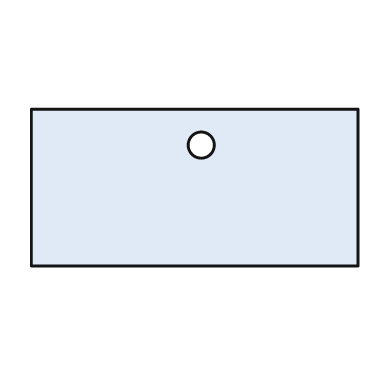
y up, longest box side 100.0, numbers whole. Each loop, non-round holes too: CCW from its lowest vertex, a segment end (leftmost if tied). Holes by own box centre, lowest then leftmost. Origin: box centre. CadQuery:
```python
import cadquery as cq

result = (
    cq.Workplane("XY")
    .moveTo(-50.0, -24.0)
    .lineTo(50.0, -24.0)
    .lineTo(50.0, 24.0)
    .lineTo(-50.0, 24.0)
    .close()
    .moveTo(2.0, 13.0)
    .circle(4.0)
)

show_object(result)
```